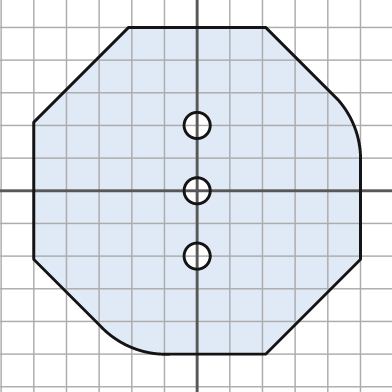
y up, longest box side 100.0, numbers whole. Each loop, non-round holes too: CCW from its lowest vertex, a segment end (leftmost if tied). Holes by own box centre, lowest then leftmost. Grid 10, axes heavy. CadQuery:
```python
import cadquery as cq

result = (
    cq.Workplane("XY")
    .moveTo(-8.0, -50.0)
    .lineTo(21.0, -50.0)
    .lineTo(50.0, -21.0)
    .lineTo(50.0, 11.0)
    .threePointArc((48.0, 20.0), (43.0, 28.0))
    .lineTo(21.0, 50.0)
    .lineTo(-21.0, 50.0)
    .lineTo(-50.0, 21.0)
    .lineTo(-50.0, -21.0)
    .lineTo(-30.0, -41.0)
    .threePointArc((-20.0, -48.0), (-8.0, -50.0))
    .close()
    .moveTo(0.0, -20.0)
    .circle(4.0)
    .moveTo(0.0, 0.0)
    .circle(4.0)
    .moveTo(0.0, 20.0)
    .circle(4.0)
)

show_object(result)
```